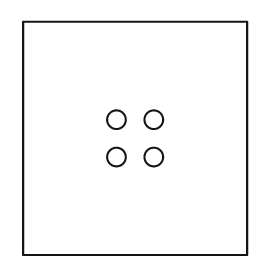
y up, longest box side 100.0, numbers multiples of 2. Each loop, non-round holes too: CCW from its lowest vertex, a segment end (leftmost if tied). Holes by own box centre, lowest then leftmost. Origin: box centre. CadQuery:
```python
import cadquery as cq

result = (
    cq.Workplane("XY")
    .moveTo(-48.0, -50.0)
    .lineTo(48.0, -50.0)
    .lineTo(48.0, 50.0)
    .lineTo(-48.0, 50.0)
    .close()
    .moveTo(-8.0, -8.0)
    .circle(4.0)
    .moveTo(8.0, -8.0)
    .circle(4.0)
    .moveTo(-8.0, 8.0)
    .circle(4.0)
    .moveTo(8.0, 8.0)
    .circle(4.0)
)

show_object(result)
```